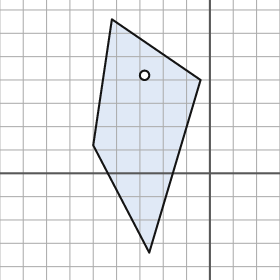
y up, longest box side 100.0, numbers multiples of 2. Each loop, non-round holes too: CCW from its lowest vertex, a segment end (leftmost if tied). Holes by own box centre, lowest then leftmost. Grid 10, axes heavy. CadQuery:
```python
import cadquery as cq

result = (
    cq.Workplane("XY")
    .moveTo(-26.0, -34.0)
    .lineTo(-4.0, 40.0)
    .lineTo(-42.0, 66.0)
    .lineTo(-50.0, 12.0)
    .close()
    .moveTo(-28.0, 42.0)
    .circle(2.0)
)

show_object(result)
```